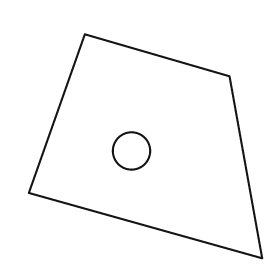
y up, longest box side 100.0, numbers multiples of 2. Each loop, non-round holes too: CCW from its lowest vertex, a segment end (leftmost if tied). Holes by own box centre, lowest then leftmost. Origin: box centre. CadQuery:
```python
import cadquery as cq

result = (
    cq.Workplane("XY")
    .moveTo(50.0, -48.0)
    .lineTo(36.0, 30.0)
    .lineTo(-26.0, 48.0)
    .lineTo(-50.0, -20.0)
    .close()
    .moveTo(-6.0, -2.0)
    .circle(8.0)
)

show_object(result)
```